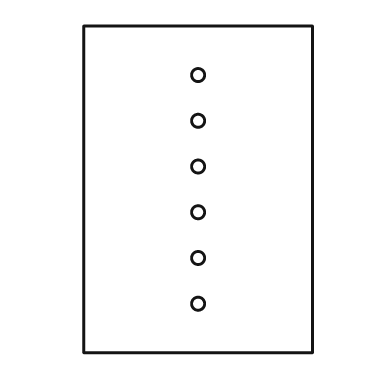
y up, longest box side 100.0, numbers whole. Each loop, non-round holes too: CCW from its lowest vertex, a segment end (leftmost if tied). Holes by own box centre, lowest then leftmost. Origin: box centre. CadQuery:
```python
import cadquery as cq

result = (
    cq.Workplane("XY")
    .moveTo(-35.0, -50.0)
    .lineTo(35.0, -50.0)
    .lineTo(35.0, 50.0)
    .lineTo(-35.0, 50.0)
    .close()
    .moveTo(0.0, -35.0)
    .circle(2.0)
    .moveTo(0.0, -21.0)
    .circle(2.0)
    .moveTo(0.0, -7.0)
    .circle(2.0)
    .moveTo(0.0, 7.0)
    .circle(2.0)
    .moveTo(0.0, 21.0)
    .circle(2.0)
    .moveTo(0.0, 35.0)
    .circle(2.0)
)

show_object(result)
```